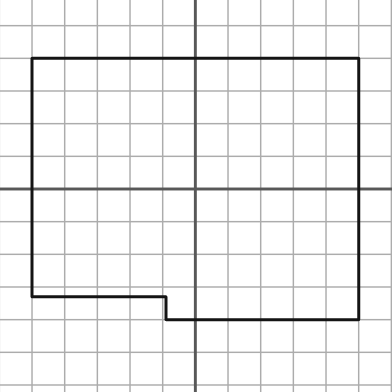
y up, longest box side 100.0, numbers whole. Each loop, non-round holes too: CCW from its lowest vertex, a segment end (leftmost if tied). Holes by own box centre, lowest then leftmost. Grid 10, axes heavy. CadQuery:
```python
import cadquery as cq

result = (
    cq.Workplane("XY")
    .moveTo(-9.0, -40.0)
    .lineTo(50.0, -40.0)
    .lineTo(50.0, 40.0)
    .lineTo(-50.0, 40.0)
    .lineTo(-50.0, -33.0)
    .lineTo(-9.0, -33.0)
    .close()
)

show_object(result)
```